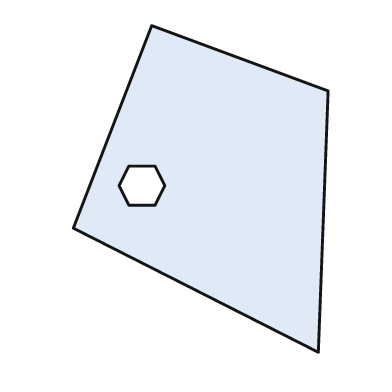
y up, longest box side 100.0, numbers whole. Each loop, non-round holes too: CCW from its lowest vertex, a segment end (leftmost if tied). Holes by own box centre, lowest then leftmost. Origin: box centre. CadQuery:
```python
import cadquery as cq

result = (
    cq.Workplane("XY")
    .moveTo(36.0, -50.0)
    .lineTo(39.0, 30.0)
    .lineTo(-15.0, 50.0)
    .lineTo(-39.0, -12.0)
    .close()
    .moveTo(-22.0, -5.0)
    .lineTo(-14.0, -5.0)
    .lineTo(-11.0, 1.0)
    .lineTo(-14.0, 7.0)
    .lineTo(-22.0, 7.0)
    .lineTo(-25.0, 1.0)
    .close()
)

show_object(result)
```